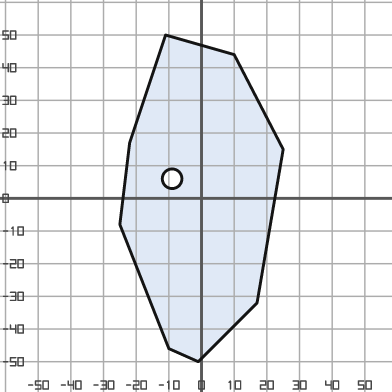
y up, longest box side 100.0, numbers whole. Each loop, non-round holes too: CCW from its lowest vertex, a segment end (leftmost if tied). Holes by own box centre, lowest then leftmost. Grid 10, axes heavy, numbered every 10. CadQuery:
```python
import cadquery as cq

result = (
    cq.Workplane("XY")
    .moveTo(-1.0, -50.0)
    .lineTo(17.0, -32.0)
    .lineTo(25.0, 15.0)
    .lineTo(10.0, 44.0)
    .lineTo(-11.0, 50.0)
    .lineTo(-22.0, 17.0)
    .lineTo(-25.0, -8.0)
    .lineTo(-10.0, -46.0)
    .close()
    .moveTo(-9.0, 6.0)
    .circle(3.0)
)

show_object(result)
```